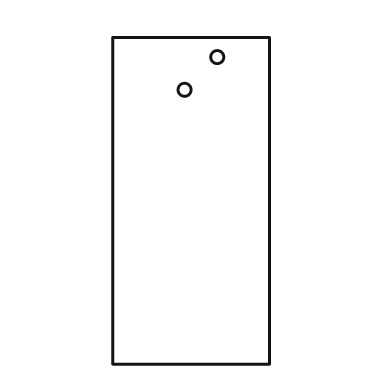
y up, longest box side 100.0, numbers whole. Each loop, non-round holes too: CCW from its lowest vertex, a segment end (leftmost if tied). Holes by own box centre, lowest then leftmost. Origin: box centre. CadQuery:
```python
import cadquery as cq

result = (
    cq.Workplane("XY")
    .moveTo(-24.0, -50.0)
    .lineTo(24.0, -50.0)
    .lineTo(24.0, 50.0)
    .lineTo(-24.0, 50.0)
    .close()
    .moveTo(-2.0, 34.0)
    .circle(2.0)
    .moveTo(8.0, 44.0)
    .circle(2.0)
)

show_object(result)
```